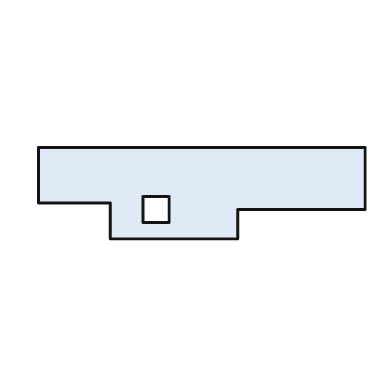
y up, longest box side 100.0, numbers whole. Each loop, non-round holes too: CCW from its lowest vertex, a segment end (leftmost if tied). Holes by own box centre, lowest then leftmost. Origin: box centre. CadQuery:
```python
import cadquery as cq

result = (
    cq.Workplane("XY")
    .moveTo(-28.0, -14.0)
    .lineTo(11.0, -14.0)
    .lineTo(11.0, -5.0)
    .lineTo(50.0, -5.0)
    .lineTo(50.0, 14.0)
    .lineTo(-50.0, 14.0)
    .lineTo(-50.0, -3.0)
    .lineTo(-28.0, -3.0)
    .close()
    .moveTo(-18.0, -9.0)
    .lineTo(-10.0, -9.0)
    .lineTo(-10.0, -1.0)
    .lineTo(-18.0, -1.0)
    .close()
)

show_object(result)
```